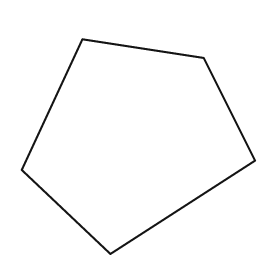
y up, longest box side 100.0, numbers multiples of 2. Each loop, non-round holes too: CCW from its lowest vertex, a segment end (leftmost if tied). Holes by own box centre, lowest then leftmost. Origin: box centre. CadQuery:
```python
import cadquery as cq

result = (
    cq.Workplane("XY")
    .moveTo(-12.0, -46.0)
    .lineTo(50.0, -6.0)
    .lineTo(28.0, 38.0)
    .lineTo(-24.0, 46.0)
    .lineTo(-50.0, -10.0)
    .close()
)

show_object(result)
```